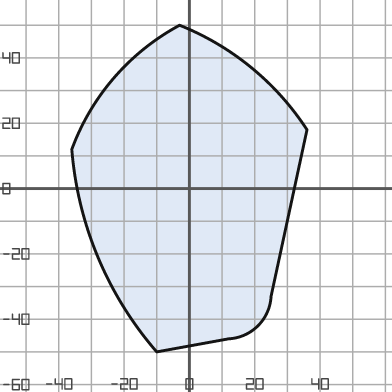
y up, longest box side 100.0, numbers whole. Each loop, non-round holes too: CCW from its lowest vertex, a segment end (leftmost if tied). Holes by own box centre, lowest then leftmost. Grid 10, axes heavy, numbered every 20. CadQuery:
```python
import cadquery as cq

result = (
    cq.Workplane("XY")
    .moveTo(-10.0, -50.0)
    .lineTo(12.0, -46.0)
    .threePointArc((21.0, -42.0), (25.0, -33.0))
    .lineTo(36.0, 18.0)
    .threePointArc((19.0, 37.0), (-3.0, 50.0))
    .threePointArc((-23.0, 34.0), (-36.0, 12.0))
    .threePointArc((-28.0, -21.0), (-10.0, -50.0))
    .close()
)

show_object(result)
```